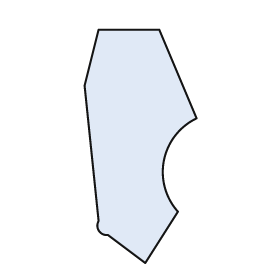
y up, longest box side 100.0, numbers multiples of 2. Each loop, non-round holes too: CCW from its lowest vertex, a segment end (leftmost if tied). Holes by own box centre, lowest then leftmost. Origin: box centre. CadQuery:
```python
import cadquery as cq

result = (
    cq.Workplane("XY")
    .moveTo(2.0, -50.0)
    .lineTo(16.0, -28.0)
    .threePointArc((10.0, -6.0), (24.0, 12.0))
    .lineTo(8.0, 50.0)
    .lineTo(-18.0, 50.0)
    .lineTo(-24.0, 26.0)
    .lineTo(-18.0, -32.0)
    .threePointArc((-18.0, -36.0), (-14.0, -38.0))
    .close()
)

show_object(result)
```